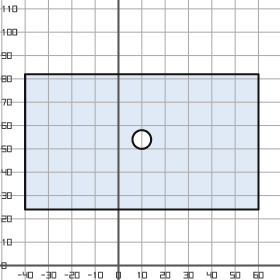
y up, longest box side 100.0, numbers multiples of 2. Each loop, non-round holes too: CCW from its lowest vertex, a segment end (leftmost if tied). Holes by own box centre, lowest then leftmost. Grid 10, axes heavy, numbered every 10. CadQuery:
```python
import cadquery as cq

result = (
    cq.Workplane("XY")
    .moveTo(-40.0, 24.0)
    .lineTo(60.0, 24.0)
    .lineTo(60.0, 82.0)
    .lineTo(-40.0, 82.0)
    .close()
    .moveTo(10.0, 54.0)
    .circle(4.0)
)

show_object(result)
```